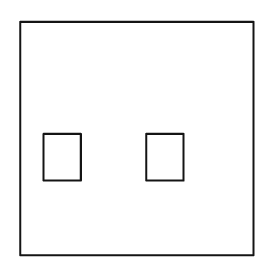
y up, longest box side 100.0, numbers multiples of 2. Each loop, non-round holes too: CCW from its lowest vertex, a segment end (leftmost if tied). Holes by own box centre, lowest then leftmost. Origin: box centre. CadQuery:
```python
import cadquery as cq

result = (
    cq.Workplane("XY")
    .moveTo(-50.0, -50.0)
    .lineTo(50.0, -50.0)
    .lineTo(50.0, 50.0)
    .lineTo(-50.0, 50.0)
    .close()
    .moveTo(-40.0, -18.0)
    .lineTo(-24.0, -18.0)
    .lineTo(-24.0, 2.0)
    .lineTo(-40.0, 2.0)
    .close()
    .moveTo(4.0, -18.0)
    .lineTo(20.0, -18.0)
    .lineTo(20.0, 2.0)
    .lineTo(4.0, 2.0)
    .close()
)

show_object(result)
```